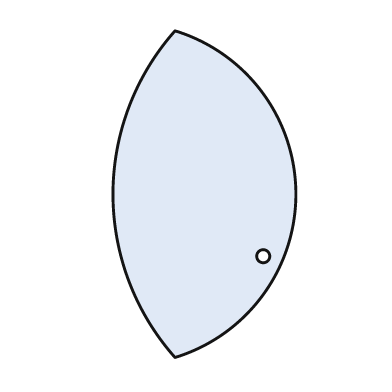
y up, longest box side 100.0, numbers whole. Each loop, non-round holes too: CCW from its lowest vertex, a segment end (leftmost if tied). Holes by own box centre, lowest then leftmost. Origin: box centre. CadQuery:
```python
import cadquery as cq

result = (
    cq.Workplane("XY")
    .moveTo(-9.0, -50.0)
    .threePointArc((28.0, 0.0), (-9.0, 50.0))
    .threePointArc((-28.0, 0.0), (-9.0, -50.0))
    .close()
    .moveTo(18.0, -19.0)
    .circle(2.0)
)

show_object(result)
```